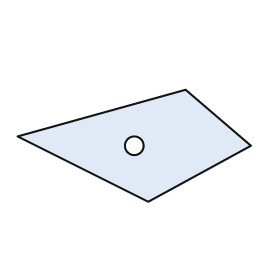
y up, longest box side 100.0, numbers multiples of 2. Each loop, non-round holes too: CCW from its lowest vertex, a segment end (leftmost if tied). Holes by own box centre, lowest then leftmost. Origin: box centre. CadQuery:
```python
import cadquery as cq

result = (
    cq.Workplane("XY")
    .moveTo(6.0, -24.0)
    .lineTo(50.0, 0.0)
    .lineTo(22.0, 24.0)
    .lineTo(-50.0, 4.0)
    .close()
    .moveTo(0.0, 0.0)
    .circle(4.0)
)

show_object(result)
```